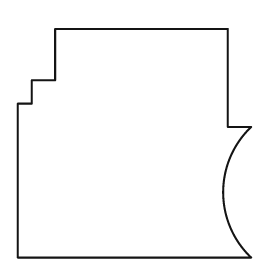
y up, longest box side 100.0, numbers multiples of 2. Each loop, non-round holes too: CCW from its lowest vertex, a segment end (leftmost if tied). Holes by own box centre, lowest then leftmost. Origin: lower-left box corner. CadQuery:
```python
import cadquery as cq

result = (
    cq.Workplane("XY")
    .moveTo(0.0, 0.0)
    .lineTo(100.0, 0.0)
    .threePointArc((88.0, 28.0), (100.0, 56.0))
    .lineTo(90.0, 56.0)
    .lineTo(90.0, 98.0)
    .lineTo(16.0, 98.0)
    .lineTo(16.0, 76.0)
    .lineTo(6.0, 76.0)
    .lineTo(6.0, 66.0)
    .lineTo(0.0, 66.0)
    .close()
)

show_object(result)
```